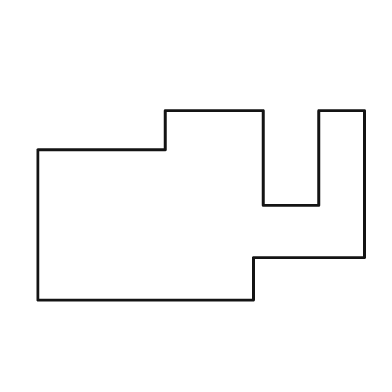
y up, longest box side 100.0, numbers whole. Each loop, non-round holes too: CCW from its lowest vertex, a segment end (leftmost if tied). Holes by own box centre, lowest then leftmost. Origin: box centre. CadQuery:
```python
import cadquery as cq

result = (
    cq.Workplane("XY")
    .moveTo(-50.0, -29.0)
    .lineTo(16.0, -29.0)
    .lineTo(16.0, -16.0)
    .lineTo(50.0, -16.0)
    .lineTo(50.0, 29.0)
    .lineTo(36.0, 29.0)
    .lineTo(36.0, 0.0)
    .lineTo(19.0, 0.0)
    .lineTo(19.0, 29.0)
    .lineTo(-11.0, 29.0)
    .lineTo(-11.0, 17.0)
    .lineTo(-50.0, 17.0)
    .close()
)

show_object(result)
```